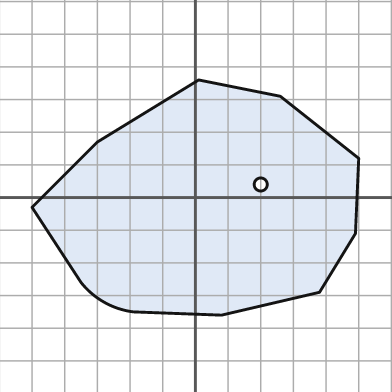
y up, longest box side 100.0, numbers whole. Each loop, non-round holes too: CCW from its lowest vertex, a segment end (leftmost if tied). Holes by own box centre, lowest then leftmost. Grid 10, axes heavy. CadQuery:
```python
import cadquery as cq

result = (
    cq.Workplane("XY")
    .moveTo(8.0, -36.0)
    .lineTo(38.0, -29.0)
    .lineTo(49.0, -11.0)
    .lineTo(50.0, 12.0)
    .lineTo(26.0, 31.0)
    .lineTo(1.0, 36.0)
    .lineTo(-30.0, 17.0)
    .lineTo(-50.0, -3.0)
    .lineTo(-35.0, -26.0)
    .threePointArc((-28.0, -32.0), (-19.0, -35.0))
    .close()
    .moveTo(20.0, 4.0)
    .circle(2.0)
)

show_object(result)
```